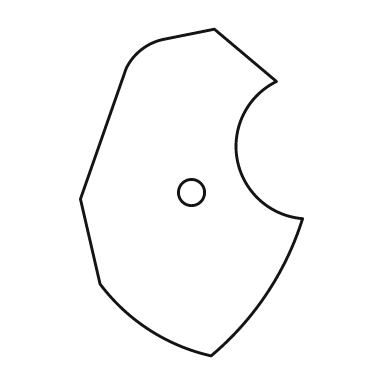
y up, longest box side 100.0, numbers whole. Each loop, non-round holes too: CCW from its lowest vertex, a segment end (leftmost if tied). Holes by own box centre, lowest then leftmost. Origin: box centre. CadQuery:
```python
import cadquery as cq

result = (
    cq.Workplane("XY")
    .moveTo(6.0, -50.0)
    .threePointArc((23.0, -31.0), (34.0, -8.0))
    .threePointArc((14.0, 10.0), (26.0, 34.0))
    .lineTo(7.0, 50.0)
    .lineTo(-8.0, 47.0)
    .threePointArc((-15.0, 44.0), (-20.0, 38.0))
    .lineTo(-34.0, -2.0)
    .lineTo(-28.0, -28.0)
    .threePointArc((-13.0, -42.0), (6.0, -50.0))
    .close()
    .moveTo(0.0, 0.0)
    .circle(4.0)
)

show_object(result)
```